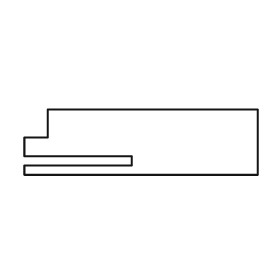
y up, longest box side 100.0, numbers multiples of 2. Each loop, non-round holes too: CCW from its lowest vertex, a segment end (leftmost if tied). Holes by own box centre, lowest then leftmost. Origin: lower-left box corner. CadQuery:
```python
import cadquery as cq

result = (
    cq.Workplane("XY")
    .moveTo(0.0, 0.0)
    .lineTo(100.0, 0.0)
    .lineTo(100.0, 28.0)
    .lineTo(10.0, 28.0)
    .lineTo(10.0, 16.0)
    .lineTo(0.0, 16.0)
    .lineTo(0.0, 8.0)
    .lineTo(46.0, 8.0)
    .lineTo(46.0, 4.0)
    .lineTo(0.0, 4.0)
    .close()
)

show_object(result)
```